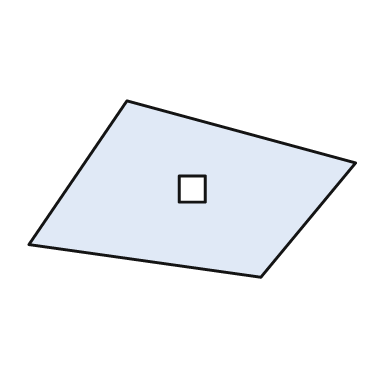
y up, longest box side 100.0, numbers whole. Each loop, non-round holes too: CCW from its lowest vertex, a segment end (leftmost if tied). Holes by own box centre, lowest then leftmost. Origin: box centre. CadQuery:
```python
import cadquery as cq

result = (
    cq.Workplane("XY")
    .moveTo(21.0, -27.0)
    .lineTo(50.0, 8.0)
    .lineTo(-20.0, 27.0)
    .lineTo(-50.0, -17.0)
    .close()
    .moveTo(-4.0, -4.0)
    .lineTo(4.0, -4.0)
    .lineTo(4.0, 4.0)
    .lineTo(-4.0, 4.0)
    .close()
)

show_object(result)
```